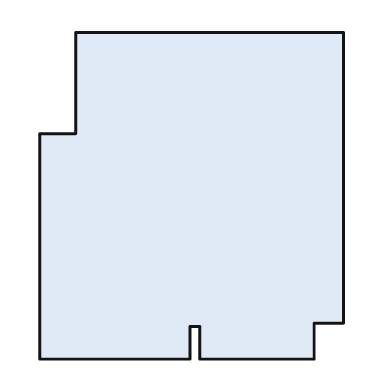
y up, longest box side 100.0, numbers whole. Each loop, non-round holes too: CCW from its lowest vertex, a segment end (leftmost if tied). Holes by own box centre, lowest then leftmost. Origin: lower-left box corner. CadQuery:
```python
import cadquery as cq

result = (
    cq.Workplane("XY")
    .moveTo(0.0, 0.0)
    .lineTo(46.0, 0.0)
    .lineTo(46.0, 10.0)
    .lineTo(49.0, 10.0)
    .lineTo(49.0, 0.0)
    .lineTo(84.0, 0.0)
    .lineTo(84.0, 11.0)
    .lineTo(93.0, 11.0)
    .lineTo(93.0, 100.0)
    .lineTo(11.0, 100.0)
    .lineTo(11.0, 69.0)
    .lineTo(0.0, 69.0)
    .close()
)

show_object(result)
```